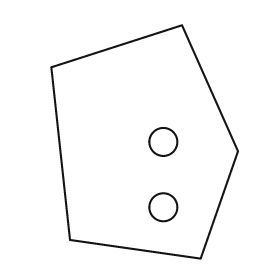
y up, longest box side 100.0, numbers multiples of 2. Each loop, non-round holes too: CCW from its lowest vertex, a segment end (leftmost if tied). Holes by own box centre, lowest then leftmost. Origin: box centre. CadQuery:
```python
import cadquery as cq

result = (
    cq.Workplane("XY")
    .moveTo(24.0, -50.0)
    .lineTo(40.0, -4.0)
    .lineTo(16.0, 50.0)
    .lineTo(-40.0, 32.0)
    .lineTo(-32.0, -42.0)
    .close()
    .moveTo(8.0, -28.0)
    .circle(6.0)
    .moveTo(8.0, 0.0)
    .circle(6.0)
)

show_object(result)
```